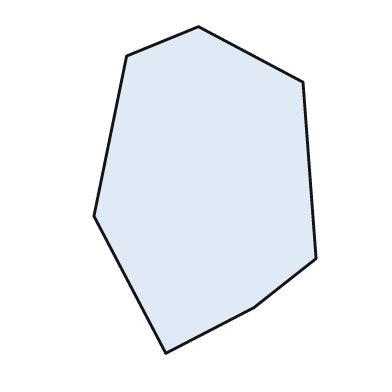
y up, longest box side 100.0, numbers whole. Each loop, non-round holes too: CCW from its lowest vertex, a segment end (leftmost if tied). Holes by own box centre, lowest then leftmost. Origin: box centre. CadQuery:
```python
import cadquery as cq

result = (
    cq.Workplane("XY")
    .moveTo(-12.0, -50.0)
    .lineTo(15.0, -36.0)
    .lineTo(34.0, -21.0)
    .lineTo(30.0, 33.0)
    .lineTo(-2.0, 50.0)
    .lineTo(-24.0, 41.0)
    .lineTo(-34.0, -8.0)
    .close()
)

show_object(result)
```